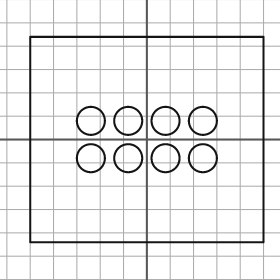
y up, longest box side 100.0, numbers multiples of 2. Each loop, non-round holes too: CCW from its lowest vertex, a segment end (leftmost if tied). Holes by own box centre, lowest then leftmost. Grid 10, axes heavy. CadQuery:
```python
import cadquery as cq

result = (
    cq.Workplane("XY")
    .moveTo(-50.0, -44.0)
    .lineTo(50.0, -44.0)
    .lineTo(50.0, 44.0)
    .lineTo(-50.0, 44.0)
    .close()
    .moveTo(-24.0, -8.0)
    .circle(6.0)
    .moveTo(-8.0, -8.0)
    .circle(6.0)
    .moveTo(8.0, -8.0)
    .circle(6.0)
    .moveTo(24.0, -8.0)
    .circle(6.0)
    .moveTo(-24.0, 8.0)
    .circle(6.0)
    .moveTo(-8.0, 8.0)
    .circle(6.0)
    .moveTo(8.0, 8.0)
    .circle(6.0)
    .moveTo(24.0, 8.0)
    .circle(6.0)
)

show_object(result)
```